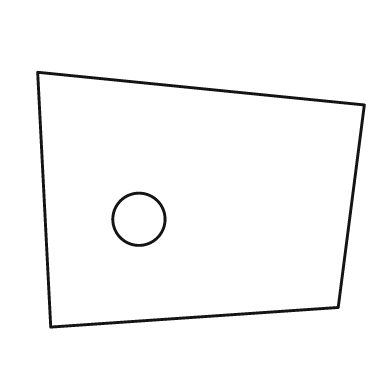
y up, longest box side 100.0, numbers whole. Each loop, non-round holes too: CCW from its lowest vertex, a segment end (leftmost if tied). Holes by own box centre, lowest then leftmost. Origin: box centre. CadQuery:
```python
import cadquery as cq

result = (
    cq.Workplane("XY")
    .moveTo(-46.0, -39.0)
    .lineTo(42.0, -33.0)
    .lineTo(50.0, 29.0)
    .lineTo(-50.0, 39.0)
    .close()
    .moveTo(-19.0, -6.0)
    .circle(8.0)
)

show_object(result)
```